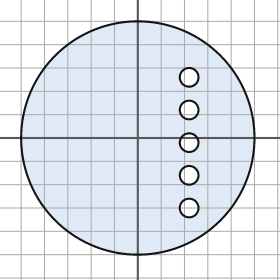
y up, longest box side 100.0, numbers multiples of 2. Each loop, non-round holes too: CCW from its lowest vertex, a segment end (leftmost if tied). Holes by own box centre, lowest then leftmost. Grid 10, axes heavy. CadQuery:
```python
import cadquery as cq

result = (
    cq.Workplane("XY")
    .moveTo(0.0, 0.0)
    .circle(50.0)
    .moveTo(22.0, -30.0)
    .circle(4.0)
    .moveTo(22.0, -16.0)
    .circle(4.0)
    .moveTo(22.0, -2.0)
    .circle(4.0)
    .moveTo(22.0, 12.0)
    .circle(4.0)
    .moveTo(22.0, 26.0)
    .circle(4.0)
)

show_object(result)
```